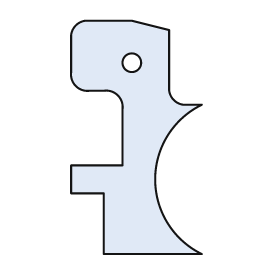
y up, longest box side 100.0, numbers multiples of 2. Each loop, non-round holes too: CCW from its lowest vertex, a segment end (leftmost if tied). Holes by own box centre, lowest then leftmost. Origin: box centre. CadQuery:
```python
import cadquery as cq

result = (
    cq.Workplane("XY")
    .moveTo(-14.0, -50.0)
    .lineTo(28.0, -50.0)
    .threePointArc((8.0, -18.0), (28.0, 14.0))
    .lineTo(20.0, 14.0)
    .threePointArc((16.0, 16.0), (14.0, 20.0))
    .lineTo(14.0, 46.0)
    .lineTo(-2.0, 50.0)
    .lineTo(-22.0, 50.0)
    .threePointArc((-26.0, 48.0), (-28.0, 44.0))
    .lineTo(-28.0, 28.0)
    .threePointArc((-26.0, 22.0), (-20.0, 20.0))
    .lineTo(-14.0, 20.0)
    .threePointArc((-8.0, 18.0), (-6.0, 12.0))
    .lineTo(-6.0, -12.0)
    .lineTo(-28.0, -12.0)
    .lineTo(-28.0, -24.0)
    .lineTo(-14.0, -24.0)
    .close()
    .moveTo(-2.0, 32.0)
    .circle(4.0)
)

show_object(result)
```